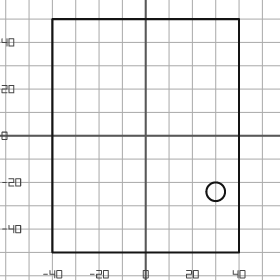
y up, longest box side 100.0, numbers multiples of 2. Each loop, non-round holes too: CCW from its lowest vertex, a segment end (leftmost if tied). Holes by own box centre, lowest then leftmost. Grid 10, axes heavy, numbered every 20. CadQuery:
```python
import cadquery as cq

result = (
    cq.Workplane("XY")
    .moveTo(-40.0, -50.0)
    .lineTo(40.0, -50.0)
    .lineTo(40.0, 50.0)
    .lineTo(-40.0, 50.0)
    .close()
    .moveTo(30.0, -24.0)
    .circle(4.0)
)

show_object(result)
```